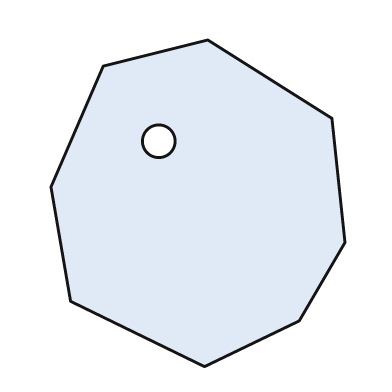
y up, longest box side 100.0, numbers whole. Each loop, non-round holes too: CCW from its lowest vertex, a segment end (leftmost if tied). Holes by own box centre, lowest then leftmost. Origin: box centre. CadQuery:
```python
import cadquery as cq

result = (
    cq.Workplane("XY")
    .moveTo(2.0, -50.0)
    .lineTo(31.0, -36.0)
    .lineTo(45.0, -12.0)
    .lineTo(41.0, 26.0)
    .lineTo(3.0, 50.0)
    .lineTo(-29.0, 42.0)
    .lineTo(-45.0, 5.0)
    .lineTo(-39.0, -30.0)
    .close()
    .moveTo(-12.0, 19.0)
    .circle(5.0)
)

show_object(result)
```